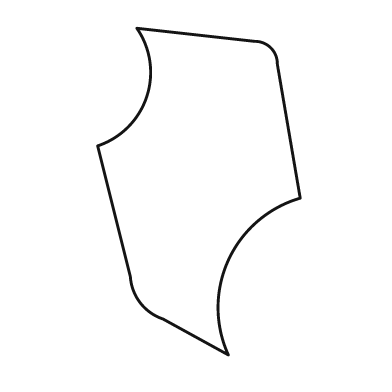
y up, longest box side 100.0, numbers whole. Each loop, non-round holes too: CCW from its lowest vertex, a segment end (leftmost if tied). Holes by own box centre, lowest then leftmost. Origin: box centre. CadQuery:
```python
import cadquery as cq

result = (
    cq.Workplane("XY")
    .moveTo(9.0, -50.0)
    .threePointArc((9.0, -21.0), (31.0, -2.0))
    .lineTo(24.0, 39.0)
    .threePointArc((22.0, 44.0), (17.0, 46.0))
    .lineTo(-19.0, 50.0)
    .threePointArc((-16.0, 29.0), (-31.0, 14.0))
    .lineTo(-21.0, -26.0)
    .threePointArc((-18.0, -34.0), (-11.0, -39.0))
    .close()
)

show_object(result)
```